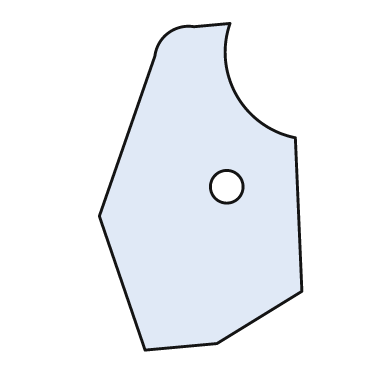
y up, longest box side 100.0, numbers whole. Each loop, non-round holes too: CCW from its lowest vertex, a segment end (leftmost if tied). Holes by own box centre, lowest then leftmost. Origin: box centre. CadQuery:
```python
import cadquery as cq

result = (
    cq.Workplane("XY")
    .moveTo(-17.0, -50.0)
    .lineTo(5.0, -48.0)
    .lineTo(31.0, -32.0)
    .lineTo(29.0, 15.0)
    .threePointArc((11.0, 28.0), (9.0, 50.0))
    .lineTo(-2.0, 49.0)
    .threePointArc((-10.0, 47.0), (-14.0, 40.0))
    .lineTo(-31.0, -9.0)
    .close()
    .moveTo(8.0, 0.0)
    .circle(5.0)
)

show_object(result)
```